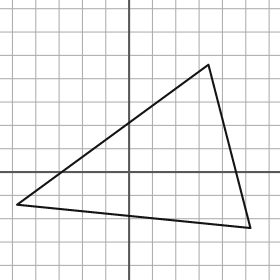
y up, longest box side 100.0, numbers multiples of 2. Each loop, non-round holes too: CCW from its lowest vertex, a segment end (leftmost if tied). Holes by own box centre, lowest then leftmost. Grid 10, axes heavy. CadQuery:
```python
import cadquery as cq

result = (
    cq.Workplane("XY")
    .moveTo(52.0, -24.0)
    .lineTo(34.0, 46.0)
    .lineTo(-48.0, -14.0)
    .close()
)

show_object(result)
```